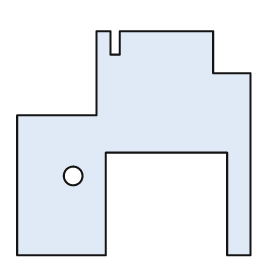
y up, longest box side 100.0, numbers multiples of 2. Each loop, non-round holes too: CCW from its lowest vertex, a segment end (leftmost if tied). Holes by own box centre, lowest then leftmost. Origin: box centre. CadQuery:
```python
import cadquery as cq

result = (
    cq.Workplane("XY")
    .moveTo(-50.0, -48.0)
    .lineTo(-12.0, -48.0)
    .lineTo(-12.0, -4.0)
    .lineTo(40.0, -4.0)
    .lineTo(40.0, -48.0)
    .lineTo(50.0, -48.0)
    .lineTo(50.0, 30.0)
    .lineTo(34.0, 30.0)
    .lineTo(34.0, 48.0)
    .lineTo(-6.0, 48.0)
    .lineTo(-6.0, 38.0)
    .lineTo(-10.0, 38.0)
    .lineTo(-10.0, 48.0)
    .lineTo(-16.0, 48.0)
    .lineTo(-16.0, 12.0)
    .lineTo(-50.0, 12.0)
    .close()
    .moveTo(-26.0, -14.0)
    .circle(4.0)
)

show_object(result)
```